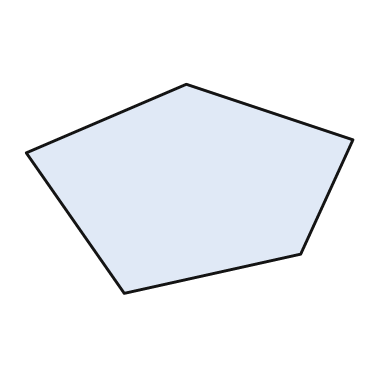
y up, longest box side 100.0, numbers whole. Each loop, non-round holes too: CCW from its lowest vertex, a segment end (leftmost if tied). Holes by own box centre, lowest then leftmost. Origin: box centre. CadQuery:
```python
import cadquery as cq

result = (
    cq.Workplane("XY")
    .moveTo(-20.0, -32.0)
    .lineTo(34.0, -20.0)
    .lineTo(50.0, 15.0)
    .lineTo(-1.0, 32.0)
    .lineTo(-50.0, 11.0)
    .close()
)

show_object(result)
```